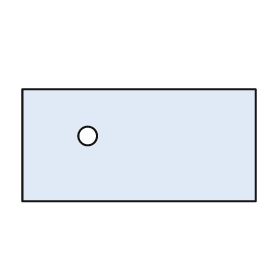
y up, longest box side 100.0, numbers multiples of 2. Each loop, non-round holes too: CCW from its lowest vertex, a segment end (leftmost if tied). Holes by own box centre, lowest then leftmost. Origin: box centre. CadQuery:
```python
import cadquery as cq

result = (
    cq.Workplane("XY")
    .moveTo(-50.0, -24.0)
    .lineTo(50.0, -24.0)
    .lineTo(50.0, 24.0)
    .lineTo(-50.0, 24.0)
    .close()
    .moveTo(-22.0, 4.0)
    .circle(4.0)
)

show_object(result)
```